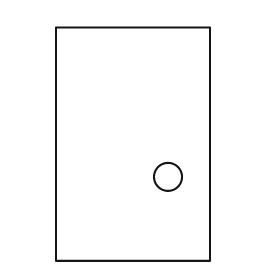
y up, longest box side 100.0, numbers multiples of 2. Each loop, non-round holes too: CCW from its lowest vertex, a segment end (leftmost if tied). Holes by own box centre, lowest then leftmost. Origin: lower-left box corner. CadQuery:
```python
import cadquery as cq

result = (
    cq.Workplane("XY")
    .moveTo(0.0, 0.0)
    .lineTo(66.0, 0.0)
    .lineTo(66.0, 100.0)
    .lineTo(0.0, 100.0)
    .close()
    .moveTo(48.0, 36.0)
    .circle(6.0)
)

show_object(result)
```